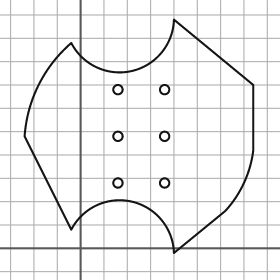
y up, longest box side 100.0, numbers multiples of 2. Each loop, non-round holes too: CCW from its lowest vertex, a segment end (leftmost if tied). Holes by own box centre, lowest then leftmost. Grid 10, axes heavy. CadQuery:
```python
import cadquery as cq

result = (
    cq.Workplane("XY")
    .moveTo(40.0, -2.0)
    .lineTo(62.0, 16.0)
    .threePointArc((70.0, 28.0), (74.0, 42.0))
    .lineTo(74.0, 70.0)
    .lineTo(40.0, 98.0)
    .threePointArc((22.0, 76.0), (-4.0, 88.0))
    .threePointArc((-18.0, 70.0), (-24.0, 48.0))
    .lineTo(-4.0, 8.0)
    .threePointArc((22.0, 20.0), (40.0, -2.0))
    .close()
    .moveTo(16.0, 28.0)
    .circle(2.0)
    .moveTo(36.0, 28.0)
    .circle(2.0)
    .moveTo(16.0, 48.0)
    .circle(2.0)
    .moveTo(36.0, 48.0)
    .circle(2.0)
    .moveTo(16.0, 68.0)
    .circle(2.0)
    .moveTo(36.0, 68.0)
    .circle(2.0)
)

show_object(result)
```